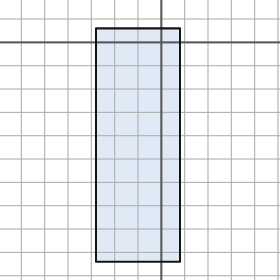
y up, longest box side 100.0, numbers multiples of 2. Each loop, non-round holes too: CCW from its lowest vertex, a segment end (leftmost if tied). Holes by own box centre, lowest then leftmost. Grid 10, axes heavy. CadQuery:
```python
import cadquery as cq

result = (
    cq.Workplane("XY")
    .moveTo(-28.0, -94.0)
    .lineTo(8.0, -94.0)
    .lineTo(8.0, 6.0)
    .lineTo(-28.0, 6.0)
    .close()
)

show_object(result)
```